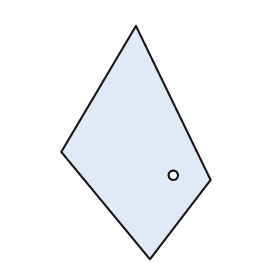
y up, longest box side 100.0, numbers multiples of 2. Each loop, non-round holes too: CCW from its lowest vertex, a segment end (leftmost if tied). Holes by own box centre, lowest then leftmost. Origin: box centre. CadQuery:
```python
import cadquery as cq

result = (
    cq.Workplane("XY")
    .moveTo(6.0, -50.0)
    .lineTo(32.0, -16.0)
    .lineTo(0.0, 50.0)
    .lineTo(-32.0, -4.0)
    .close()
    .moveTo(16.0, -14.0)
    .circle(2.0)
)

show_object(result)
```